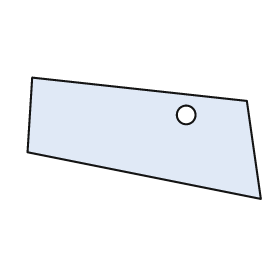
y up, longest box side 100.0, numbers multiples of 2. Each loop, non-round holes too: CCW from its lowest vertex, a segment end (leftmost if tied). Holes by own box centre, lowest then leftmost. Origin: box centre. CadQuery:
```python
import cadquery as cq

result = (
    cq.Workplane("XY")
    .moveTo(50.0, -26.0)
    .lineTo(44.0, 16.0)
    .lineTo(-48.0, 26.0)
    .lineTo(-50.0, -6.0)
    .close()
    .moveTo(18.0, 10.0)
    .circle(4.0)
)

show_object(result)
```